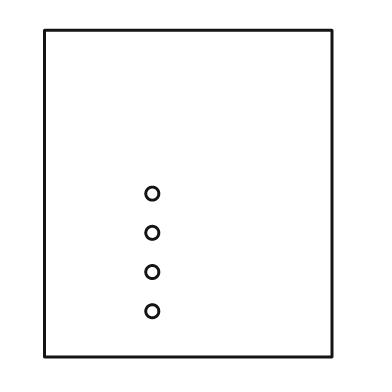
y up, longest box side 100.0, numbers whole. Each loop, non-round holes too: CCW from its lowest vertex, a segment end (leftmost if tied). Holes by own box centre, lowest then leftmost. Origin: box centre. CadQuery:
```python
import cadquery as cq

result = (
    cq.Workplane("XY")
    .moveTo(-44.0, -50.0)
    .lineTo(44.0, -50.0)
    .lineTo(44.0, 50.0)
    .lineTo(-44.0, 50.0)
    .close()
    .moveTo(-11.0, -36.0)
    .circle(2.0)
    .moveTo(-11.0, -24.0)
    .circle(2.0)
    .moveTo(-11.0, -12.0)
    .circle(2.0)
    .moveTo(-11.0, 0.0)
    .circle(2.0)
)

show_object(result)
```